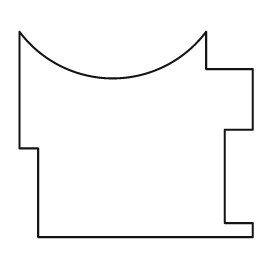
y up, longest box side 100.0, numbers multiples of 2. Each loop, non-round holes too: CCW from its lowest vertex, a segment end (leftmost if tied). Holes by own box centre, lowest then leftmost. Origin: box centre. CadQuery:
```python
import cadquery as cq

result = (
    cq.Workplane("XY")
    .moveTo(-42.0, -44.0)
    .lineTo(50.0, -44.0)
    .lineTo(50.0, -38.0)
    .lineTo(38.0, -38.0)
    .lineTo(38.0, 2.0)
    .lineTo(50.0, 2.0)
    .lineTo(50.0, 28.0)
    .lineTo(30.0, 28.0)
    .lineTo(30.0, 44.0)
    .threePointArc((-10.0, 24.0), (-50.0, 44.0))
    .lineTo(-50.0, -6.0)
    .lineTo(-42.0, -6.0)
    .close()
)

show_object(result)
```